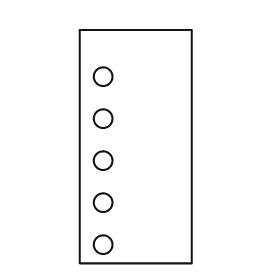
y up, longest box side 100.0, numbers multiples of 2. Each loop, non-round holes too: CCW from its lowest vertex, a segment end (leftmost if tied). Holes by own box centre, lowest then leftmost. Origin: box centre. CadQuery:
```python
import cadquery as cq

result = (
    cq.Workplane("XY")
    .moveTo(-24.0, -50.0)
    .lineTo(24.0, -50.0)
    .lineTo(24.0, 50.0)
    .lineTo(-24.0, 50.0)
    .close()
    .moveTo(-14.0, -42.0)
    .circle(4.0)
    .moveTo(-14.0, -24.0)
    .circle(4.0)
    .moveTo(-14.0, -6.0)
    .circle(4.0)
    .moveTo(-14.0, 12.0)
    .circle(4.0)
    .moveTo(-14.0, 30.0)
    .circle(4.0)
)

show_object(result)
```